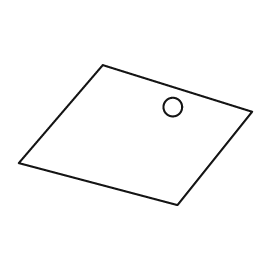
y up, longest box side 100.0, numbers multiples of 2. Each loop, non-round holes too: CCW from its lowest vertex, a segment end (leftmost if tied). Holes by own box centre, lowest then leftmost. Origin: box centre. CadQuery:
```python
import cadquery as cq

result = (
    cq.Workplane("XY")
    .moveTo(18.0, -30.0)
    .lineTo(50.0, 10.0)
    .lineTo(-14.0, 30.0)
    .lineTo(-50.0, -12.0)
    .close()
    .moveTo(16.0, 12.0)
    .circle(4.0)
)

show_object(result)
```